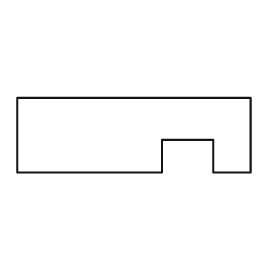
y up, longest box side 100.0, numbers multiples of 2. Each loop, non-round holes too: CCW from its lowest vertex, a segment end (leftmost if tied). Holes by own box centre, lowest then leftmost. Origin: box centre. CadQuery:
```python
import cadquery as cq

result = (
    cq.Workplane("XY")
    .moveTo(-50.0, -16.0)
    .lineTo(12.0, -16.0)
    .lineTo(12.0, -2.0)
    .lineTo(34.0, -2.0)
    .lineTo(34.0, -16.0)
    .lineTo(50.0, -16.0)
    .lineTo(50.0, 16.0)
    .lineTo(-50.0, 16.0)
    .close()
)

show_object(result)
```